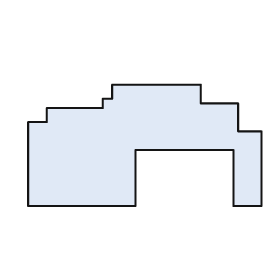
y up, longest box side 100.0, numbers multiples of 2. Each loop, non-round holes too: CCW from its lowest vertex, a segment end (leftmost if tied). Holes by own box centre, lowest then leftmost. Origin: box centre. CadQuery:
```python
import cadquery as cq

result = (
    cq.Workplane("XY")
    .moveTo(-50.0, -26.0)
    .lineTo(-4.0, -26.0)
    .lineTo(-4.0, -2.0)
    .lineTo(38.0, -2.0)
    .lineTo(38.0, -26.0)
    .lineTo(50.0, -26.0)
    .lineTo(50.0, 6.0)
    .lineTo(40.0, 6.0)
    .lineTo(40.0, 18.0)
    .lineTo(24.0, 18.0)
    .lineTo(24.0, 26.0)
    .lineTo(-14.0, 26.0)
    .lineTo(-14.0, 20.0)
    .lineTo(-18.0, 20.0)
    .lineTo(-18.0, 16.0)
    .lineTo(-42.0, 16.0)
    .lineTo(-42.0, 10.0)
    .lineTo(-50.0, 10.0)
    .close()
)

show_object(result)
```